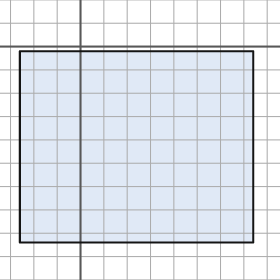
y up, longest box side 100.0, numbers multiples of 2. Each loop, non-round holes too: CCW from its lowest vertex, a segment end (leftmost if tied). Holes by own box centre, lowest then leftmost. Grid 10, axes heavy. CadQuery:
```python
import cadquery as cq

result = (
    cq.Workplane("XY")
    .moveTo(-26.0, -84.0)
    .lineTo(74.0, -84.0)
    .lineTo(74.0, -2.0)
    .lineTo(-26.0, -2.0)
    .close()
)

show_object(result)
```